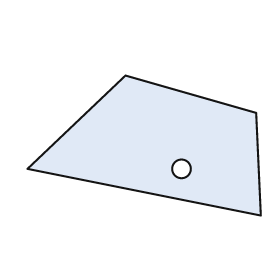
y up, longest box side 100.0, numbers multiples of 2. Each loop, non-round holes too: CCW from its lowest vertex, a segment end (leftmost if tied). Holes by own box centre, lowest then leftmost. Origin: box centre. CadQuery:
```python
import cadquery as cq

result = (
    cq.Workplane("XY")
    .moveTo(50.0, -30.0)
    .lineTo(48.0, 14.0)
    .lineTo(-8.0, 30.0)
    .lineTo(-50.0, -10.0)
    .close()
    .moveTo(16.0, -10.0)
    .circle(4.0)
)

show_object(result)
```